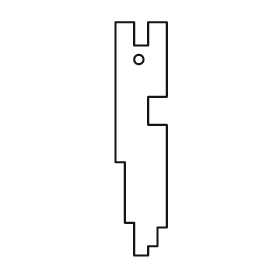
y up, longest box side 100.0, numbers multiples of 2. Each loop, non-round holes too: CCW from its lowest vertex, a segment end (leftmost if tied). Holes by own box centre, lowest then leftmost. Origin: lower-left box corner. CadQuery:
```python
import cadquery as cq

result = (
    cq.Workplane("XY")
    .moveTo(8.0, 0.0)
    .lineTo(14.0, 0.0)
    .lineTo(14.0, 4.0)
    .lineTo(18.0, 4.0)
    .lineTo(18.0, 12.0)
    .lineTo(22.0, 12.0)
    .lineTo(22.0, 56.0)
    .lineTo(14.0, 56.0)
    .lineTo(14.0, 68.0)
    .lineTo(22.0, 68.0)
    .lineTo(22.0, 100.0)
    .lineTo(14.0, 100.0)
    .lineTo(14.0, 90.0)
    .lineTo(8.0, 90.0)
    .lineTo(8.0, 100.0)
    .lineTo(0.0, 100.0)
    .lineTo(0.0, 40.0)
    .lineTo(4.0, 40.0)
    .lineTo(4.0, 14.0)
    .lineTo(8.0, 14.0)
    .close()
    .moveTo(10.0, 84.0)
    .circle(2.0)
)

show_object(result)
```